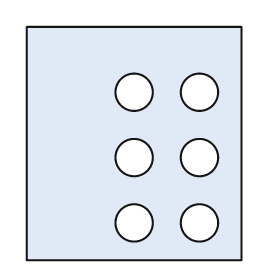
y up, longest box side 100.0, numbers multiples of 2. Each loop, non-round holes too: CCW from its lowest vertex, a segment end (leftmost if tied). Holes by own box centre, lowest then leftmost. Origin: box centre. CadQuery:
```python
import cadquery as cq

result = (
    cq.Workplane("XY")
    .moveTo(-46.0, -50.0)
    .lineTo(46.0, -50.0)
    .lineTo(46.0, 50.0)
    .lineTo(-46.0, 50.0)
    .close()
    .moveTo(0.0, -34.0)
    .circle(8.0)
    .moveTo(28.0, -34.0)
    .circle(8.0)
    .moveTo(0.0, -6.0)
    .circle(8.0)
    .moveTo(28.0, -6.0)
    .circle(8.0)
    .moveTo(0.0, 22.0)
    .circle(8.0)
    .moveTo(28.0, 22.0)
    .circle(8.0)
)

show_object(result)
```